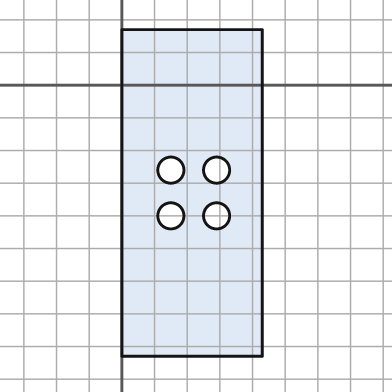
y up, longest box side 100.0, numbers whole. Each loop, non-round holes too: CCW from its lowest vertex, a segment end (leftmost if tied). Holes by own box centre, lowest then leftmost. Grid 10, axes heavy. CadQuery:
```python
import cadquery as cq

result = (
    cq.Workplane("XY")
    .moveTo(0.0, -83.0)
    .lineTo(43.0, -83.0)
    .lineTo(43.0, 17.0)
    .lineTo(0.0, 17.0)
    .close()
    .moveTo(15.0, -40.0)
    .circle(4.0)
    .moveTo(29.0, -40.0)
    .circle(4.0)
    .moveTo(15.0, -26.0)
    .circle(4.0)
    .moveTo(29.0, -26.0)
    .circle(4.0)
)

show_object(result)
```